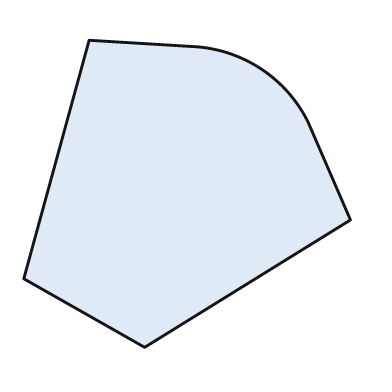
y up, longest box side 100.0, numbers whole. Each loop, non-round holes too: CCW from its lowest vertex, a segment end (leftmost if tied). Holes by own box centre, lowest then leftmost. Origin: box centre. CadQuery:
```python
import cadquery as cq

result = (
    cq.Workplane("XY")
    .moveTo(-13.0, -47.0)
    .lineTo(50.0, -8.0)
    .lineTo(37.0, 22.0)
    .threePointArc((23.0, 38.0), (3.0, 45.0))
    .lineTo(-30.0, 47.0)
    .lineTo(-50.0, -26.0)
    .close()
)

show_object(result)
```